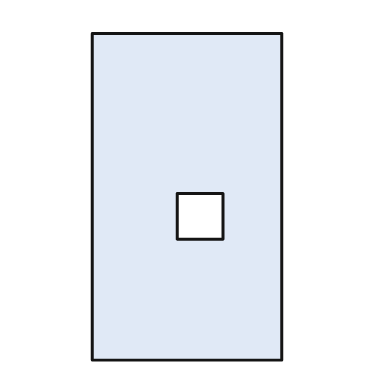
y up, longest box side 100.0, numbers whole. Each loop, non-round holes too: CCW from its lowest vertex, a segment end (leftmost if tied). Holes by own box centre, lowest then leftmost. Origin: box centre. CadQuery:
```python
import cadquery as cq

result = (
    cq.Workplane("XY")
    .moveTo(-29.0, -50.0)
    .lineTo(29.0, -50.0)
    .lineTo(29.0, 50.0)
    .lineTo(-29.0, 50.0)
    .close()
    .moveTo(-3.0, -13.0)
    .lineTo(11.0, -13.0)
    .lineTo(11.0, 1.0)
    .lineTo(-3.0, 1.0)
    .close()
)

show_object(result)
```